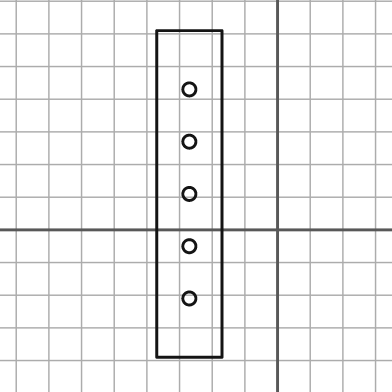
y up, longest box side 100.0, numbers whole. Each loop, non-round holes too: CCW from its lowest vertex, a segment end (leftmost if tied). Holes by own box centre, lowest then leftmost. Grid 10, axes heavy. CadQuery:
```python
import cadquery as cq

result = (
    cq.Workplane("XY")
    .moveTo(-37.0, -39.0)
    .lineTo(-17.0, -39.0)
    .lineTo(-17.0, 61.0)
    .lineTo(-37.0, 61.0)
    .close()
    .moveTo(-27.0, -21.0)
    .circle(2.0)
    .moveTo(-27.0, -5.0)
    .circle(2.0)
    .moveTo(-27.0, 11.0)
    .circle(2.0)
    .moveTo(-27.0, 27.0)
    .circle(2.0)
    .moveTo(-27.0, 43.0)
    .circle(2.0)
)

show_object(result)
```